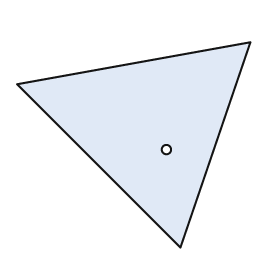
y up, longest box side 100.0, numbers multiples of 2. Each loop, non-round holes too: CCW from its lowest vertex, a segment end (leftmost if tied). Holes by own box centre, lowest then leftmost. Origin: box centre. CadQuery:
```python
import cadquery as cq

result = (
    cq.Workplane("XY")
    .moveTo(20.0, -44.0)
    .lineTo(50.0, 44.0)
    .lineTo(-50.0, 26.0)
    .close()
    .moveTo(14.0, -2.0)
    .circle(2.0)
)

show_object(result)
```